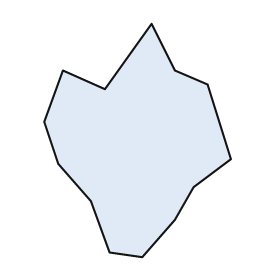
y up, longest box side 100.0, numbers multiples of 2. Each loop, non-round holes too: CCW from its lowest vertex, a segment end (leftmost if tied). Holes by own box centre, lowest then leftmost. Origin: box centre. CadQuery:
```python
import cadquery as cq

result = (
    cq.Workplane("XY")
    .moveTo(2.0, -50.0)
    .lineTo(16.0, -34.0)
    .lineTo(24.0, -20.0)
    .lineTo(40.0, -8.0)
    .lineTo(30.0, 24.0)
    .lineTo(16.0, 30.0)
    .lineTo(6.0, 50.0)
    .lineTo(-14.0, 22.0)
    .lineTo(-32.0, 30.0)
    .lineTo(-40.0, 8.0)
    .lineTo(-34.0, -10.0)
    .lineTo(-20.0, -26.0)
    .lineTo(-12.0, -48.0)
    .close()
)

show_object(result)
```